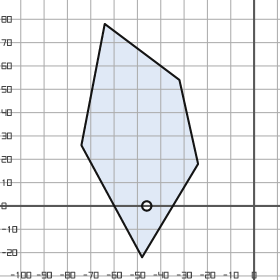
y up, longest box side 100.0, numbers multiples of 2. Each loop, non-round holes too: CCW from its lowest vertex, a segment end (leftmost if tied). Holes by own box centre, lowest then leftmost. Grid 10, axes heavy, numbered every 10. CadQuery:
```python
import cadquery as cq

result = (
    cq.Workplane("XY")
    .moveTo(-48.0, -22.0)
    .lineTo(-24.0, 18.0)
    .lineTo(-32.0, 54.0)
    .lineTo(-64.0, 78.0)
    .lineTo(-74.0, 26.0)
    .close()
    .moveTo(-46.0, 0.0)
    .circle(2.0)
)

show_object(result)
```